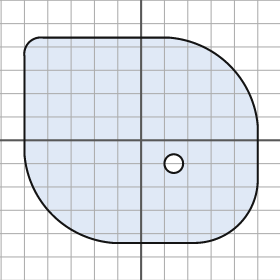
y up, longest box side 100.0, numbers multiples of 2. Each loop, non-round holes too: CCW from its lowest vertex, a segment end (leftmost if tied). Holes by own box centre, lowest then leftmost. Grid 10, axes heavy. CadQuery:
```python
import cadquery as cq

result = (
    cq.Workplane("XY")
    .moveTo(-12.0, -44.0)
    .lineTo(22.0, -44.0)
    .threePointArc((42.0, -36.0), (50.0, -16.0))
    .lineTo(50.0, 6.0)
    .threePointArc((38.0, 32.0), (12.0, 44.0))
    .lineTo(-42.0, 44.0)
    .threePointArc((-48.0, 42.0), (-50.0, 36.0))
    .lineTo(-50.0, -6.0)
    .threePointArc((-38.0, -32.0), (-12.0, -44.0))
    .close()
    .moveTo(14.0, -10.0)
    .circle(4.0)
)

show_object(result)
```